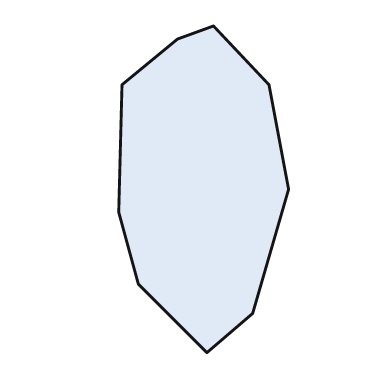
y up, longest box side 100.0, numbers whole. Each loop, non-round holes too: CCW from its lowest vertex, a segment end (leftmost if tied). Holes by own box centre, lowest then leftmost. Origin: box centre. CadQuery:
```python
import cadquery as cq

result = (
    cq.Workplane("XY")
    .moveTo(1.0, -50.0)
    .lineTo(15.0, -38.0)
    .lineTo(26.0, 0.0)
    .lineTo(20.0, 32.0)
    .lineTo(3.0, 50.0)
    .lineTo(-8.0, 46.0)
    .lineTo(-25.0, 32.0)
    .lineTo(-26.0, -7.0)
    .lineTo(-20.0, -29.0)
    .close()
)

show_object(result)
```